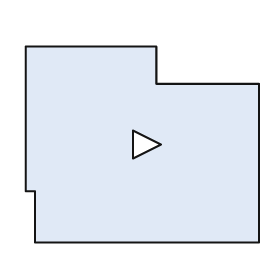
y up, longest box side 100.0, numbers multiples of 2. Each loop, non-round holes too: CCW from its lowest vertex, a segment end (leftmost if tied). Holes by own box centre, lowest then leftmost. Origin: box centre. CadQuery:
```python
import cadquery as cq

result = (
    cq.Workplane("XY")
    .moveTo(-46.0, -42.0)
    .lineTo(50.0, -42.0)
    .lineTo(50.0, 26.0)
    .lineTo(6.0, 26.0)
    .lineTo(6.0, 42.0)
    .lineTo(-50.0, 42.0)
    .lineTo(-50.0, -20.0)
    .lineTo(-46.0, -20.0)
    .close()
    .moveTo(-4.0, -6.0)
    .lineTo(8.0, 0.0)
    .lineTo(-4.0, 6.0)
    .close()
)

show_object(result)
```